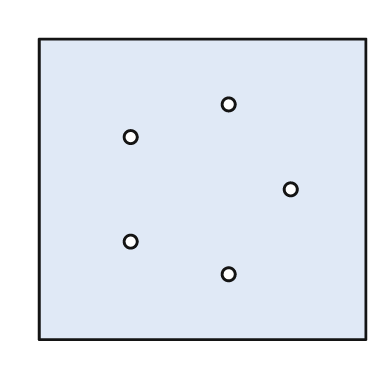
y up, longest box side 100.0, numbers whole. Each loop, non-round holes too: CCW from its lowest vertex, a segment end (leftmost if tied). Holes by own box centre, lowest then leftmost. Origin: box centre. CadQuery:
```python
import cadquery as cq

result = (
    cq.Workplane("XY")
    .moveTo(-50.0, -46.0)
    .lineTo(50.0, -46.0)
    .lineTo(50.0, 46.0)
    .lineTo(-50.0, 46.0)
    .close()
    .moveTo(8.0, -26.0)
    .circle(2.0)
    .moveTo(-22.0, -16.0)
    .circle(2.0)
    .moveTo(27.0, 0.0)
    .circle(2.0)
    .moveTo(-22.0, 16.0)
    .circle(2.0)
    .moveTo(8.0, 26.0)
    .circle(2.0)
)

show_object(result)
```